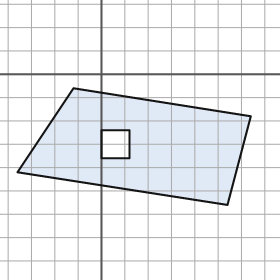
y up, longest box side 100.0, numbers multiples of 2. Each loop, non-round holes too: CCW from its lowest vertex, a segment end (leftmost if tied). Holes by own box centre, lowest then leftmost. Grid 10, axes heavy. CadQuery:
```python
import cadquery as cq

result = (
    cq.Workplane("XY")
    .moveTo(54.0, -56.0)
    .lineTo(64.0, -18.0)
    .lineTo(-12.0, -6.0)
    .lineTo(-36.0, -42.0)
    .close()
    .moveTo(0.0, -36.0)
    .lineTo(12.0, -36.0)
    .lineTo(12.0, -24.0)
    .lineTo(0.0, -24.0)
    .close()
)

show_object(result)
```